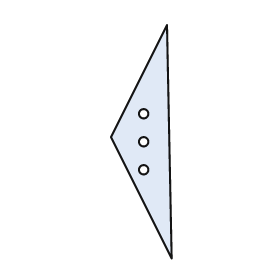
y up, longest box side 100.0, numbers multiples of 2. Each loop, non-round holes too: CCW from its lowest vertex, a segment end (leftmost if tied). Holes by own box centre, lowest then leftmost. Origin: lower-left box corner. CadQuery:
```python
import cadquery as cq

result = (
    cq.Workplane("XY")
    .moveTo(26.0, 0.0)
    .lineTo(24.0, 100.0)
    .lineTo(0.0, 52.0)
    .close()
    .moveTo(14.0, 38.0)
    .circle(2.0)
    .moveTo(14.0, 50.0)
    .circle(2.0)
    .moveTo(14.0, 62.0)
    .circle(2.0)
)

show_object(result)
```